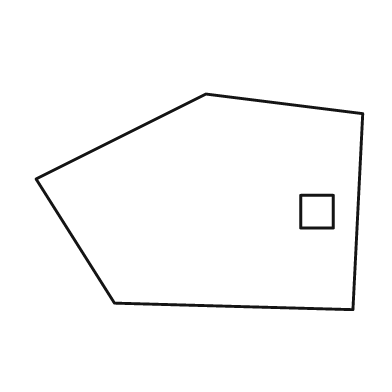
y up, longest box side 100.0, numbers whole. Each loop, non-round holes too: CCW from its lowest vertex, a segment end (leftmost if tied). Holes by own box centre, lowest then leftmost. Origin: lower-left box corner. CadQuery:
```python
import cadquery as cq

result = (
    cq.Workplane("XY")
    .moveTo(97.0, 0.0)
    .lineTo(100.0, 60.0)
    .lineTo(52.0, 66.0)
    .lineTo(0.0, 40.0)
    .lineTo(24.0, 2.0)
    .close()
    .moveTo(81.0, 25.0)
    .lineTo(91.0, 25.0)
    .lineTo(91.0, 35.0)
    .lineTo(81.0, 35.0)
    .close()
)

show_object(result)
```